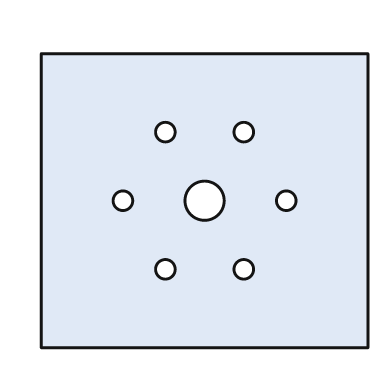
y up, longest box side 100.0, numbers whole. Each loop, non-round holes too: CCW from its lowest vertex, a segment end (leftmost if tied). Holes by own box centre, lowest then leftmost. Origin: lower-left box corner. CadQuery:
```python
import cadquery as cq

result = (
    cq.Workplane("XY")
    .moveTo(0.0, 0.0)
    .lineTo(100.0, 0.0)
    .lineTo(100.0, 90.0)
    .lineTo(0.0, 90.0)
    .close()
    .moveTo(38.0, 24.0)
    .circle(3.0)
    .moveTo(62.0, 24.0)
    .circle(3.0)
    .moveTo(25.0, 45.0)
    .circle(3.0)
    .moveTo(50.0, 45.0)
    .circle(6.0)
    .moveTo(75.0, 45.0)
    .circle(3.0)
    .moveTo(38.0, 66.0)
    .circle(3.0)
    .moveTo(62.0, 66.0)
    .circle(3.0)
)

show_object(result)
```